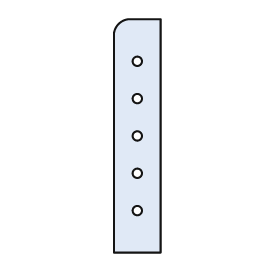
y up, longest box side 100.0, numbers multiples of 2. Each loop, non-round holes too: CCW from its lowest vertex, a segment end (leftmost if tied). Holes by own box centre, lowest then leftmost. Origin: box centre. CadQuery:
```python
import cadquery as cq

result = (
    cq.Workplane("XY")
    .moveTo(-10.0, -50.0)
    .lineTo(10.0, -50.0)
    .lineTo(10.0, 50.0)
    .lineTo(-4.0, 50.0)
    .threePointArc((-8.0, 48.0), (-10.0, 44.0))
    .close()
    .moveTo(0.0, -32.0)
    .circle(2.0)
    .moveTo(0.0, -16.0)
    .circle(2.0)
    .moveTo(0.0, 0.0)
    .circle(2.0)
    .moveTo(0.0, 16.0)
    .circle(2.0)
    .moveTo(0.0, 32.0)
    .circle(2.0)
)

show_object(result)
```